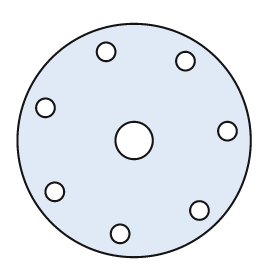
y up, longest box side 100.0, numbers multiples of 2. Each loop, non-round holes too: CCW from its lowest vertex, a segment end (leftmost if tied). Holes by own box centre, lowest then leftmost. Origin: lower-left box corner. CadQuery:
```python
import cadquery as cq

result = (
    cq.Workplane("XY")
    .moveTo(50.0, 50.0)
    .circle(50.0)
    .moveTo(44.0, 10.0)
    .circle(4.0)
    .moveTo(78.0, 20.0)
    .circle(4.0)
    .moveTo(16.0, 28.0)
    .circle(4.0)
    .moveTo(50.0, 50.0)
    .circle(8.0)
    .moveTo(90.0, 54.0)
    .circle(4.0)
    .moveTo(12.0, 64.0)
    .circle(4.0)
    .moveTo(72.0, 84.0)
    .circle(4.0)
    .moveTo(38.0, 88.0)
    .circle(4.0)
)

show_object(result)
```